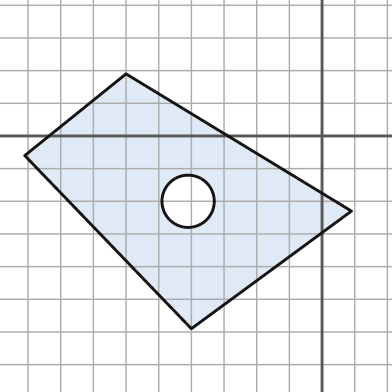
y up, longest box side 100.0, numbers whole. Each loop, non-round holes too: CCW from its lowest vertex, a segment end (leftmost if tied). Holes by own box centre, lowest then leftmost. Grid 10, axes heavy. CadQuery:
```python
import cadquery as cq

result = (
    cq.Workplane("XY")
    .moveTo(-40.0, -59.0)
    .lineTo(9.0, -23.0)
    .lineTo(-60.0, 19.0)
    .lineTo(-91.0, -6.0)
    .close()
    .moveTo(-41.0, -20.0)
    .circle(8.0)
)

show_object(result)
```